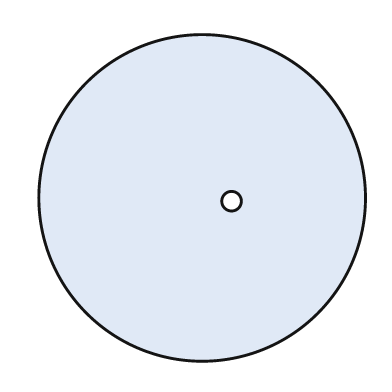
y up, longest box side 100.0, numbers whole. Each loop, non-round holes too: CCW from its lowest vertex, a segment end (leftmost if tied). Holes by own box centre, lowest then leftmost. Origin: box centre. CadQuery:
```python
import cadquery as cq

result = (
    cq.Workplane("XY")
    .moveTo(0.0, 0.0)
    .circle(50.0)
    .moveTo(9.0, -1.0)
    .circle(3.0)
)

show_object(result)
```